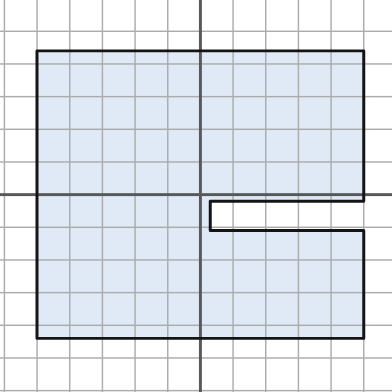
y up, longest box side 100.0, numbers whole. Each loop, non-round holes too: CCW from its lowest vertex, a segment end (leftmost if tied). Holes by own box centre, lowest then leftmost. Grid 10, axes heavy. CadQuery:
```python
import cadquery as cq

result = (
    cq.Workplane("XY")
    .moveTo(-50.0, -44.0)
    .lineTo(50.0, -44.0)
    .lineTo(50.0, -11.0)
    .lineTo(3.0, -11.0)
    .lineTo(3.0, -2.0)
    .lineTo(50.0, -2.0)
    .lineTo(50.0, 44.0)
    .lineTo(-50.0, 44.0)
    .close()
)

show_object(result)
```